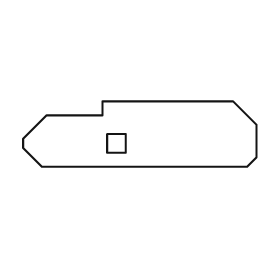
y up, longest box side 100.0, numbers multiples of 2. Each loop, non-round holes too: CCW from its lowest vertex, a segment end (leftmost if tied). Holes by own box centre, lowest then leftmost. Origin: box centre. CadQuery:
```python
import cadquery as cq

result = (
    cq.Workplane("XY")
    .moveTo(-42.0, -14.0)
    .lineTo(46.0, -14.0)
    .lineTo(50.0, -10.0)
    .lineTo(50.0, 4.0)
    .lineTo(40.0, 14.0)
    .lineTo(-16.0, 14.0)
    .lineTo(-16.0, 8.0)
    .lineTo(-40.0, 8.0)
    .lineTo(-50.0, -2.0)
    .lineTo(-50.0, -6.0)
    .close()
    .moveTo(-14.0, -8.0)
    .lineTo(-6.0, -8.0)
    .lineTo(-6.0, 0.0)
    .lineTo(-14.0, 0.0)
    .close()
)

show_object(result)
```